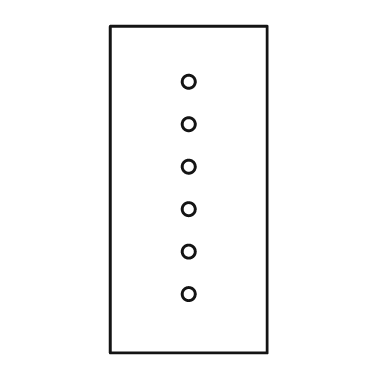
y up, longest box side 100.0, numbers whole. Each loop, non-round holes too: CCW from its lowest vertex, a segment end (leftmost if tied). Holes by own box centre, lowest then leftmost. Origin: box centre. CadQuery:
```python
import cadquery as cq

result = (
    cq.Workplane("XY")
    .moveTo(-24.0, -50.0)
    .lineTo(24.0, -50.0)
    .lineTo(24.0, 50.0)
    .lineTo(-24.0, 50.0)
    .close()
    .moveTo(0.0, -32.0)
    .circle(2.0)
    .moveTo(0.0, -19.0)
    .circle(2.0)
    .moveTo(0.0, -6.0)
    .circle(2.0)
    .moveTo(0.0, 7.0)
    .circle(2.0)
    .moveTo(0.0, 20.0)
    .circle(2.0)
    .moveTo(0.0, 33.0)
    .circle(2.0)
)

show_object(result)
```